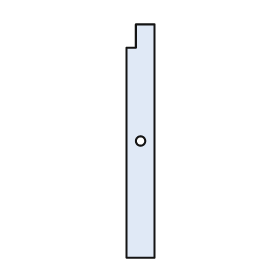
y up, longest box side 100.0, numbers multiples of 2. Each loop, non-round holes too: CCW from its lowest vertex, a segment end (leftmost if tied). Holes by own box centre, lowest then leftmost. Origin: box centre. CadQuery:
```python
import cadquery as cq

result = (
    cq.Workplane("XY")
    .moveTo(-6.0, -50.0)
    .lineTo(6.0, -50.0)
    .lineTo(6.0, 50.0)
    .lineTo(-2.0, 50.0)
    .lineTo(-2.0, 40.0)
    .lineTo(-6.0, 40.0)
    .close()
    .moveTo(0.0, 0.0)
    .circle(2.0)
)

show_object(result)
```